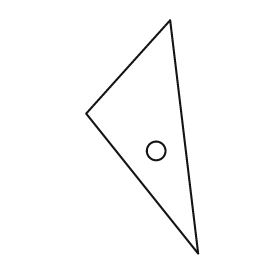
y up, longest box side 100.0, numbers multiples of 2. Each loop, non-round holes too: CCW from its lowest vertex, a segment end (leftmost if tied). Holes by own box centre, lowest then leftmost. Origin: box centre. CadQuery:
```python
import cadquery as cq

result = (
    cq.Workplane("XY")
    .moveTo(24.0, -50.0)
    .lineTo(12.0, 50.0)
    .lineTo(-24.0, 10.0)
    .close()
    .moveTo(6.0, -6.0)
    .circle(4.0)
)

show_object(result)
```